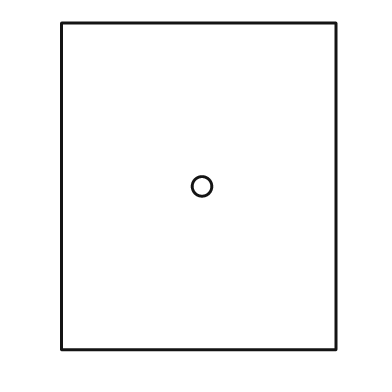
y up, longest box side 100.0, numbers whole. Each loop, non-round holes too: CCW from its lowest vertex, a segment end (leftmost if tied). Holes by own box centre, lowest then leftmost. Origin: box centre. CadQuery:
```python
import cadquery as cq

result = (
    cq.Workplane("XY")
    .moveTo(-42.0, -50.0)
    .lineTo(42.0, -50.0)
    .lineTo(42.0, 50.0)
    .lineTo(-42.0, 50.0)
    .close()
    .moveTo(1.0, 0.0)
    .circle(3.0)
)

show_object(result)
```